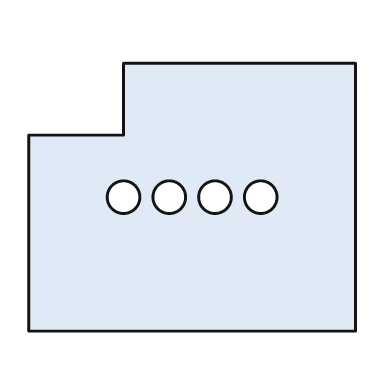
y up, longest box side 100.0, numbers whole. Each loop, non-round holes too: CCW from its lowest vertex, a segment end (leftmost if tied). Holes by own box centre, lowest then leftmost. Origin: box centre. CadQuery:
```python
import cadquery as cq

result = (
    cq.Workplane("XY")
    .moveTo(-50.0, -41.0)
    .lineTo(50.0, -41.0)
    .lineTo(50.0, 41.0)
    .lineTo(-21.0, 41.0)
    .lineTo(-21.0, 19.0)
    .lineTo(-50.0, 19.0)
    .close()
    .moveTo(-21.0, 0.0)
    .circle(5.0)
    .moveTo(-7.0, 0.0)
    .circle(5.0)
    .moveTo(7.0, 0.0)
    .circle(5.0)
    .moveTo(21.0, 0.0)
    .circle(5.0)
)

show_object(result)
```